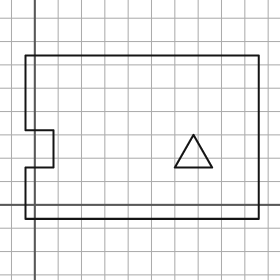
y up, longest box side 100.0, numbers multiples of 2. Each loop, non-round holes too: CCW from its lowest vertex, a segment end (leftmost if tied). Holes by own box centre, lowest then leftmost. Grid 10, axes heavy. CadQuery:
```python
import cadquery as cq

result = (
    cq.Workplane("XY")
    .moveTo(-4.0, -6.0)
    .lineTo(96.0, -6.0)
    .lineTo(96.0, 64.0)
    .lineTo(-4.0, 64.0)
    .lineTo(-4.0, 32.0)
    .lineTo(8.0, 32.0)
    .lineTo(8.0, 16.0)
    .lineTo(-4.0, 16.0)
    .close()
    .moveTo(60.0, 16.0)
    .lineTo(76.0, 16.0)
    .lineTo(68.0, 30.0)
    .close()
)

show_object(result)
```